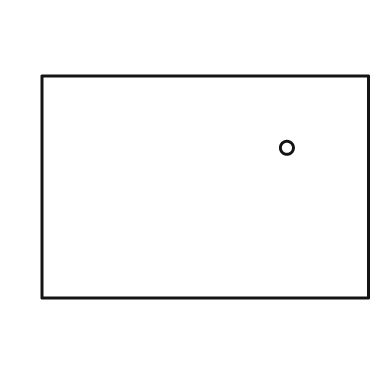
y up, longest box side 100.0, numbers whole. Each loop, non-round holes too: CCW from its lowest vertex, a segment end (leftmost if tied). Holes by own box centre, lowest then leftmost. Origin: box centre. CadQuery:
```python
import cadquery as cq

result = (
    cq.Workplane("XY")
    .moveTo(-50.0, -34.0)
    .lineTo(50.0, -34.0)
    .lineTo(50.0, 34.0)
    .lineTo(-50.0, 34.0)
    .close()
    .moveTo(25.0, 12.0)
    .circle(2.0)
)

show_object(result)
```